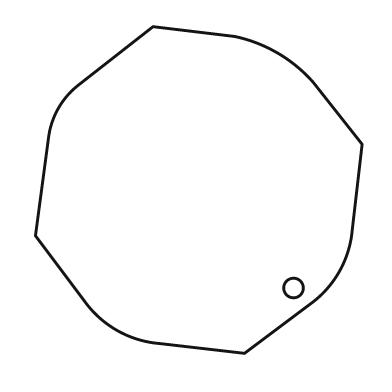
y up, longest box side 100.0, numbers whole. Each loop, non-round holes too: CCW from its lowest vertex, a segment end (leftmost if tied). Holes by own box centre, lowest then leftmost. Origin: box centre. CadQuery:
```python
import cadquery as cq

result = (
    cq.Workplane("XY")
    .moveTo(14.0, -50.0)
    .lineTo(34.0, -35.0)
    .threePointArc((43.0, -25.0), (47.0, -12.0))
    .lineTo(50.0, 14.0)
    .lineTo(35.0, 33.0)
    .threePointArc((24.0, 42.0), (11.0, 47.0))
    .lineTo(-14.0, 50.0)
    .lineTo(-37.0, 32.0)
    .threePointArc((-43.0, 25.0), (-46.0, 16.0))
    .lineTo(-50.0, -14.0)
    .lineTo(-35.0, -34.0)
    .threePointArc((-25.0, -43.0), (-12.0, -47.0))
    .close()
    .moveTo(29.0, -30.0)
    .circle(3.0)
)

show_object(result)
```